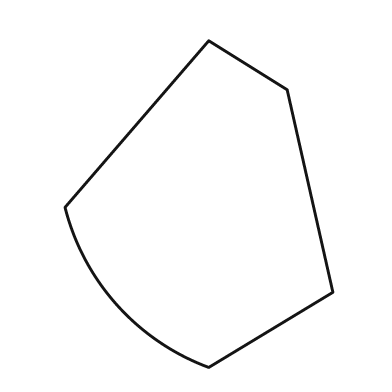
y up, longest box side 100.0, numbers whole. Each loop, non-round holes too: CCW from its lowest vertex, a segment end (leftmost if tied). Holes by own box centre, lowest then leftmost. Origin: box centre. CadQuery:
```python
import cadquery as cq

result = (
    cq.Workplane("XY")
    .moveTo(3.0, -50.0)
    .lineTo(41.0, -27.0)
    .lineTo(27.0, 35.0)
    .lineTo(3.0, 50.0)
    .lineTo(-41.0, -1.0)
    .threePointArc((-25.0, -31.0), (3.0, -50.0))
    .close()
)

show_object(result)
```